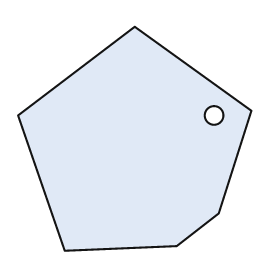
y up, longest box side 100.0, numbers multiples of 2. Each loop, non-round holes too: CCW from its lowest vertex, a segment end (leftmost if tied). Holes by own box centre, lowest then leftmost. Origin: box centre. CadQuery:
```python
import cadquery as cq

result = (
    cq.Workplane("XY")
    .moveTo(-30.0, -48.0)
    .lineTo(18.0, -46.0)
    .lineTo(36.0, -32.0)
    .lineTo(50.0, 12.0)
    .lineTo(0.0, 48.0)
    .lineTo(-50.0, 10.0)
    .close()
    .moveTo(34.0, 10.0)
    .circle(4.0)
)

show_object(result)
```